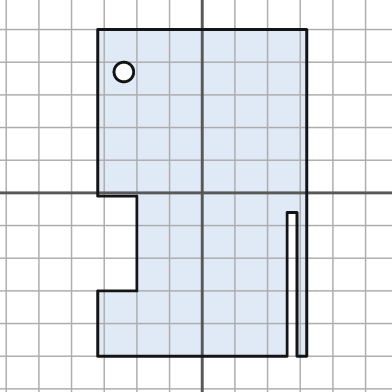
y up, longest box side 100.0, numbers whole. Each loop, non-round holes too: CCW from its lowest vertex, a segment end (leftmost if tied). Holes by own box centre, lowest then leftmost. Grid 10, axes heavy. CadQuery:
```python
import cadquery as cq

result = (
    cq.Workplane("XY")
    .moveTo(-32.0, -50.0)
    .lineTo(26.0, -50.0)
    .lineTo(26.0, -6.0)
    .lineTo(29.0, -6.0)
    .lineTo(29.0, -50.0)
    .lineTo(32.0, -50.0)
    .lineTo(32.0, 50.0)
    .lineTo(-32.0, 50.0)
    .lineTo(-32.0, -1.0)
    .lineTo(-20.0, -1.0)
    .lineTo(-20.0, -30.0)
    .lineTo(-32.0, -30.0)
    .close()
    .moveTo(-24.0, 37.0)
    .circle(3.0)
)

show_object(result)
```